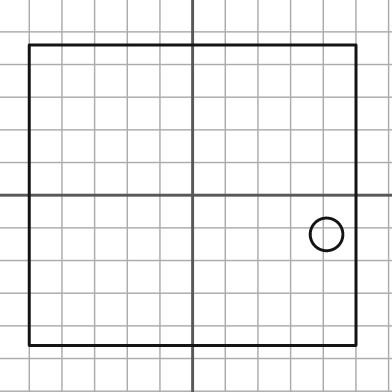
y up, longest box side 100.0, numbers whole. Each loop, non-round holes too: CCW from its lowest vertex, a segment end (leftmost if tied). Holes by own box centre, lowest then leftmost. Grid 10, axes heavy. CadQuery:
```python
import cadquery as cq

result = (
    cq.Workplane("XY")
    .moveTo(-50.0, -46.0)
    .lineTo(50.0, -46.0)
    .lineTo(50.0, 46.0)
    .lineTo(-50.0, 46.0)
    .close()
    .moveTo(41.0, -12.0)
    .circle(5.0)
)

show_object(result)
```